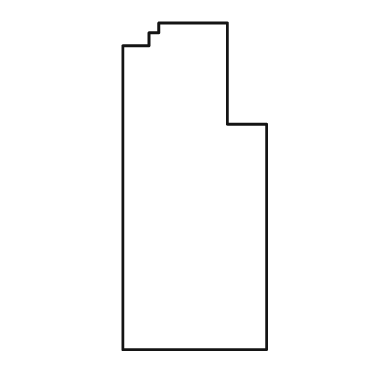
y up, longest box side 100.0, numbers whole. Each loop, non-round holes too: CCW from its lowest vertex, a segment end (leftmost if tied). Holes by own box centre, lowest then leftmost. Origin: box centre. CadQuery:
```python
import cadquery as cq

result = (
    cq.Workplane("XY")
    .moveTo(-22.0, -50.0)
    .lineTo(22.0, -50.0)
    .lineTo(22.0, 19.0)
    .lineTo(10.0, 19.0)
    .lineTo(10.0, 50.0)
    .lineTo(-11.0, 50.0)
    .lineTo(-11.0, 47.0)
    .lineTo(-14.0, 47.0)
    .lineTo(-14.0, 43.0)
    .lineTo(-22.0, 43.0)
    .close()
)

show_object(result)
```